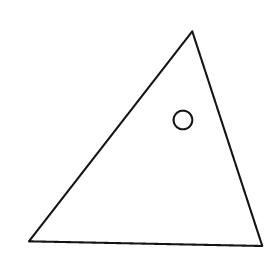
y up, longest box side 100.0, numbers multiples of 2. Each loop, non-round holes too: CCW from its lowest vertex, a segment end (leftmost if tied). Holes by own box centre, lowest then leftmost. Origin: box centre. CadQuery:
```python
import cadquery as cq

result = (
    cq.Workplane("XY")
    .moveTo(50.0, -46.0)
    .lineTo(20.0, 46.0)
    .lineTo(-50.0, -44.0)
    .close()
    .moveTo(16.0, 8.0)
    .circle(4.0)
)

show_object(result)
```